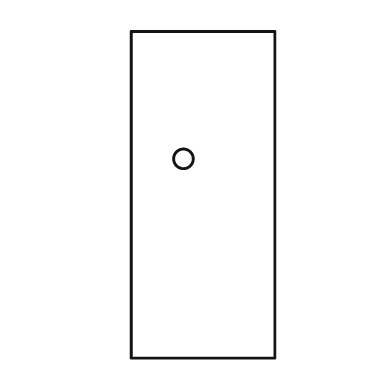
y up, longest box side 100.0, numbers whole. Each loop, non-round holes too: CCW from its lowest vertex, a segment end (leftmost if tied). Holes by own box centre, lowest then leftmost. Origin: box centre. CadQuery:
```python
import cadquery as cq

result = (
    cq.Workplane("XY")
    .moveTo(-22.0, -50.0)
    .lineTo(22.0, -50.0)
    .lineTo(22.0, 50.0)
    .lineTo(-22.0, 50.0)
    .close()
    .moveTo(-6.0, 11.0)
    .circle(3.0)
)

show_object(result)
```